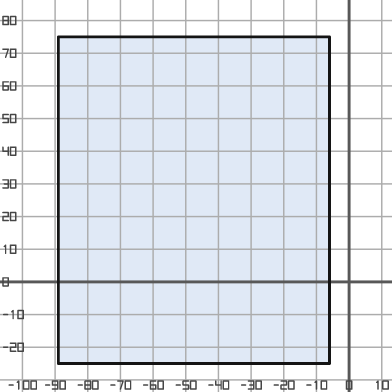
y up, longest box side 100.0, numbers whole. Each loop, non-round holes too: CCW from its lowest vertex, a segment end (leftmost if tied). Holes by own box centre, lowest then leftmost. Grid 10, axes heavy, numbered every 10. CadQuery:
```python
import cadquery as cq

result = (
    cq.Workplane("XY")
    .moveTo(-89.0, -25.0)
    .lineTo(-6.0, -25.0)
    .lineTo(-6.0, 75.0)
    .lineTo(-89.0, 75.0)
    .close()
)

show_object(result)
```